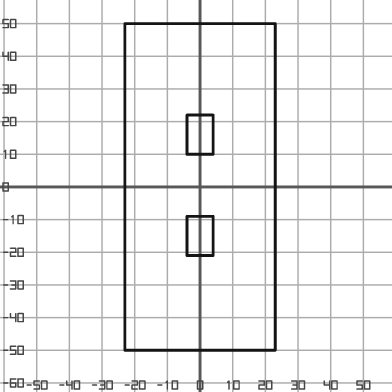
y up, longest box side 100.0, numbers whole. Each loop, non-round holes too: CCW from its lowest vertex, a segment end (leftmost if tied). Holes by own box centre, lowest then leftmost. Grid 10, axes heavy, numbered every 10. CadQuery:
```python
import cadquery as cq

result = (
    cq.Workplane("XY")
    .moveTo(-23.0, -50.0)
    .lineTo(23.0, -50.0)
    .lineTo(23.0, 50.0)
    .lineTo(-23.0, 50.0)
    .close()
    .moveTo(-4.0, -21.0)
    .lineTo(4.0, -21.0)
    .lineTo(4.0, -9.0)
    .lineTo(-4.0, -9.0)
    .close()
    .moveTo(-4.0, 10.0)
    .lineTo(4.0, 10.0)
    .lineTo(4.0, 22.0)
    .lineTo(-4.0, 22.0)
    .close()
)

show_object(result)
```